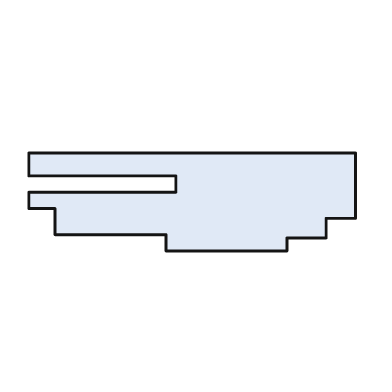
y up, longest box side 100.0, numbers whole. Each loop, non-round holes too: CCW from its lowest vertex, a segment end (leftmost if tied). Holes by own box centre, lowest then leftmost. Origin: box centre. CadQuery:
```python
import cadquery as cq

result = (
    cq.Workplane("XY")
    .moveTo(-8.0, -15.0)
    .lineTo(29.0, -15.0)
    .lineTo(29.0, -11.0)
    .lineTo(41.0, -11.0)
    .lineTo(41.0, -5.0)
    .lineTo(50.0, -5.0)
    .lineTo(50.0, 15.0)
    .lineTo(-50.0, 15.0)
    .lineTo(-50.0, 8.0)
    .lineTo(-5.0, 8.0)
    .lineTo(-5.0, 3.0)
    .lineTo(-50.0, 3.0)
    .lineTo(-50.0, -2.0)
    .lineTo(-42.0, -2.0)
    .lineTo(-42.0, -10.0)
    .lineTo(-8.0, -10.0)
    .close()
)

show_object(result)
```